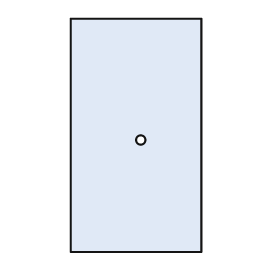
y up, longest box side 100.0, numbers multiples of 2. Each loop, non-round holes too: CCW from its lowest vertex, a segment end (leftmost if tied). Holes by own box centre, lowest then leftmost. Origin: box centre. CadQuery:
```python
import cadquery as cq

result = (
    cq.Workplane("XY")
    .moveTo(-28.0, -50.0)
    .lineTo(28.0, -50.0)
    .lineTo(28.0, 50.0)
    .lineTo(-28.0, 50.0)
    .close()
    .moveTo(2.0, -2.0)
    .circle(2.0)
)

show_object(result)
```